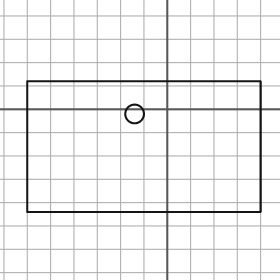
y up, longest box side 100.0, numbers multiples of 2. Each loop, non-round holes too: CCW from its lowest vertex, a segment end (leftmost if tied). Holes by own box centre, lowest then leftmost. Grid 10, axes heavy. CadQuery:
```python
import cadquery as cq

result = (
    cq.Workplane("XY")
    .moveTo(-60.0, -44.0)
    .lineTo(40.0, -44.0)
    .lineTo(40.0, 12.0)
    .lineTo(-60.0, 12.0)
    .close()
    .moveTo(-14.0, -2.0)
    .circle(4.0)
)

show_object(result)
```